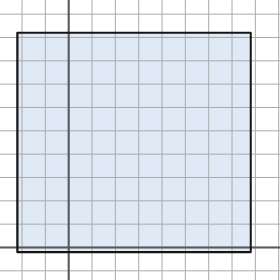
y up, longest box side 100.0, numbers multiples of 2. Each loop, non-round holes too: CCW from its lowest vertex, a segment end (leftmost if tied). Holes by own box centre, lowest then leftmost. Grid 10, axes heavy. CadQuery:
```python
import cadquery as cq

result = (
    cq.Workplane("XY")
    .moveTo(-22.0, -2.0)
    .lineTo(78.0, -2.0)
    .lineTo(78.0, 92.0)
    .lineTo(-22.0, 92.0)
    .close()
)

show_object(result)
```